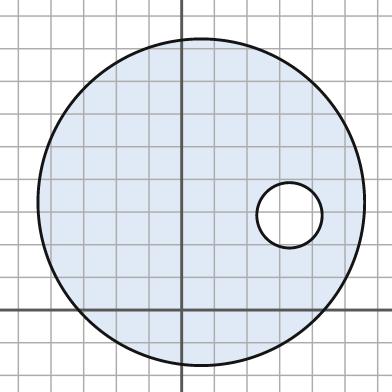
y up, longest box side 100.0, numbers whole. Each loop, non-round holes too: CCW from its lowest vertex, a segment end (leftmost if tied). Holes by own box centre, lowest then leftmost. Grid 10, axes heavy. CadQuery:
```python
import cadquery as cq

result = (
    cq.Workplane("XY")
    .moveTo(6.0, 33.0)
    .circle(50.0)
    .moveTo(33.0, 29.0)
    .circle(10.0)
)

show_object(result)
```